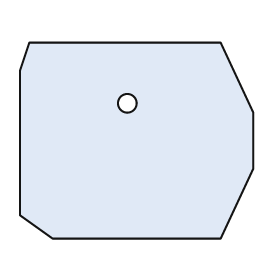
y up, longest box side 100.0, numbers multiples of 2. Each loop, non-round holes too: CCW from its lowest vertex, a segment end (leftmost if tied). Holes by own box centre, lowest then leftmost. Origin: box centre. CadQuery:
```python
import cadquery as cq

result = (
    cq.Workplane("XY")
    .moveTo(-36.0, -42.0)
    .lineTo(36.0, -42.0)
    .lineTo(50.0, -12.0)
    .lineTo(50.0, 12.0)
    .lineTo(36.0, 42.0)
    .lineTo(-46.0, 42.0)
    .lineTo(-50.0, 30.0)
    .lineTo(-50.0, -32.0)
    .close()
    .moveTo(-4.0, 16.0)
    .circle(4.0)
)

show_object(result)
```